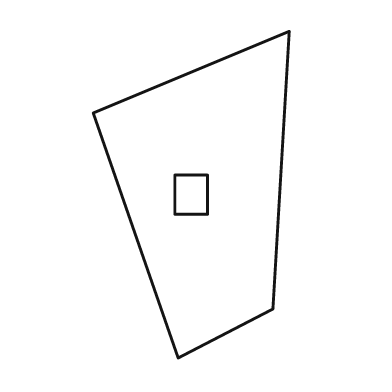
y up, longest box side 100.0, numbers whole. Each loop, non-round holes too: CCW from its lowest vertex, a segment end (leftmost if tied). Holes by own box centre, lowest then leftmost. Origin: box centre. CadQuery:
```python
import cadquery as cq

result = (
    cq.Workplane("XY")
    .moveTo(-4.0, -50.0)
    .lineTo(25.0, -35.0)
    .lineTo(30.0, 50.0)
    .lineTo(-30.0, 25.0)
    .close()
    .moveTo(-5.0, -6.0)
    .lineTo(5.0, -6.0)
    .lineTo(5.0, 6.0)
    .lineTo(-5.0, 6.0)
    .close()
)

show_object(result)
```